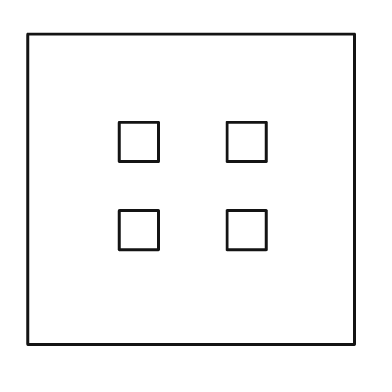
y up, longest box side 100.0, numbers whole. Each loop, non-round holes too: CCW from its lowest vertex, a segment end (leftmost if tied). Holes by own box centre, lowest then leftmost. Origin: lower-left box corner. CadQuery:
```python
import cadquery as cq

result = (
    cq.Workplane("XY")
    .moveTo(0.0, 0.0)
    .lineTo(100.0, 0.0)
    .lineTo(100.0, 95.0)
    .lineTo(0.0, 95.0)
    .close()
    .moveTo(28.0, 29.0)
    .lineTo(40.0, 29.0)
    .lineTo(40.0, 41.0)
    .lineTo(28.0, 41.0)
    .close()
    .moveTo(61.0, 29.0)
    .lineTo(73.0, 29.0)
    .lineTo(73.0, 41.0)
    .lineTo(61.0, 41.0)
    .close()
    .moveTo(28.0, 56.0)
    .lineTo(40.0, 56.0)
    .lineTo(40.0, 68.0)
    .lineTo(28.0, 68.0)
    .close()
    .moveTo(61.0, 56.0)
    .lineTo(73.0, 56.0)
    .lineTo(73.0, 68.0)
    .lineTo(61.0, 68.0)
    .close()
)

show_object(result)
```